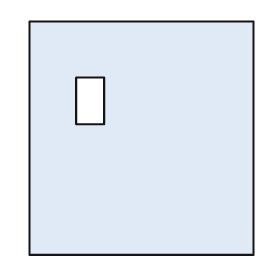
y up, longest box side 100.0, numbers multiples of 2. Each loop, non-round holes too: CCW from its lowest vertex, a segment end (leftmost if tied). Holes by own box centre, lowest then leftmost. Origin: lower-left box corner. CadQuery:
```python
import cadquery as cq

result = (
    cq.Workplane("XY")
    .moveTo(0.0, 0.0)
    .lineTo(96.0, 0.0)
    .lineTo(96.0, 100.0)
    .lineTo(0.0, 100.0)
    .close()
    .moveTo(20.0, 56.0)
    .lineTo(32.0, 56.0)
    .lineTo(32.0, 76.0)
    .lineTo(20.0, 76.0)
    .close()
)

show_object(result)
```